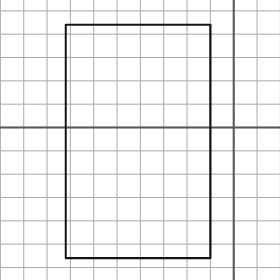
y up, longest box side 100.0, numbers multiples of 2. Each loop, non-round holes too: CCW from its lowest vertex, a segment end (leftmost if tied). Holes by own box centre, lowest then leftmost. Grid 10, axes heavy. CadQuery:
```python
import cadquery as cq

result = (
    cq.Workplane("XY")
    .moveTo(-72.0, -56.0)
    .lineTo(-10.0, -56.0)
    .lineTo(-10.0, 44.0)
    .lineTo(-72.0, 44.0)
    .close()
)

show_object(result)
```